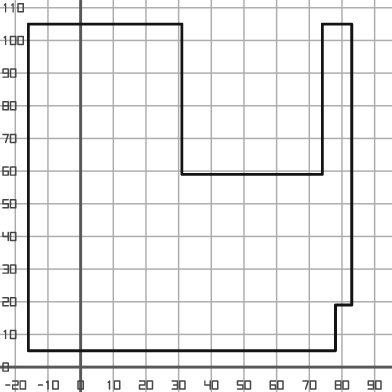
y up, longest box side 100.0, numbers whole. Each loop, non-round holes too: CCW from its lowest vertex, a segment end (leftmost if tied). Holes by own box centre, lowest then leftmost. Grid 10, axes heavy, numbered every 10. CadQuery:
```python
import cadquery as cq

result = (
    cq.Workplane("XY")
    .moveTo(-16.0, 5.0)
    .lineTo(78.0, 5.0)
    .lineTo(78.0, 19.0)
    .lineTo(83.0, 19.0)
    .lineTo(83.0, 105.0)
    .lineTo(74.0, 105.0)
    .lineTo(74.0, 59.0)
    .lineTo(31.0, 59.0)
    .lineTo(31.0, 105.0)
    .lineTo(-16.0, 105.0)
    .close()
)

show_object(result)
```